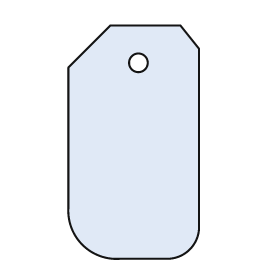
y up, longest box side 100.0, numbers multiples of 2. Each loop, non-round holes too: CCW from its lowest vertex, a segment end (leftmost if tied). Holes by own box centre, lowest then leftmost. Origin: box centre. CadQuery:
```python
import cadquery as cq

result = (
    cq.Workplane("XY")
    .moveTo(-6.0, -50.0)
    .lineTo(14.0, -50.0)
    .threePointArc((24.0, -46.0), (28.0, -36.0))
    .lineTo(28.0, 40.0)
    .lineTo(20.0, 50.0)
    .lineTo(-10.0, 50.0)
    .lineTo(-28.0, 32.0)
    .lineTo(-28.0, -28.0)
    .threePointArc((-22.0, -44.0), (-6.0, -50.0))
    .close()
    .moveTo(2.0, 34.0)
    .circle(4.0)
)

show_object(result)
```